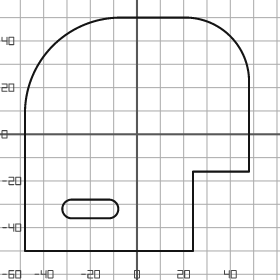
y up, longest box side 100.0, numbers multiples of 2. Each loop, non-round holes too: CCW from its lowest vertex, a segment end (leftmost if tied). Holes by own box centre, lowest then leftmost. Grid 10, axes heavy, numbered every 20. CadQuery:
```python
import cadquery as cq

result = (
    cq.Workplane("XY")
    .moveTo(-48.0, -50.0)
    .lineTo(24.0, -50.0)
    .lineTo(24.0, -16.0)
    .lineTo(48.0, -16.0)
    .lineTo(48.0, 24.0)
    .threePointArc((40.0, 42.0), (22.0, 50.0))
    .lineTo(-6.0, 50.0)
    .threePointArc((-36.0, 38.0), (-48.0, 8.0))
    .close()
    .moveTo(-28.0, -36.0)
    .lineTo(-12.0, -36.0)
    .threePointArc((-8.0, -32.0), (-12.0, -28.0))
    .lineTo(-28.0, -28.0)
    .threePointArc((-32.0, -32.0), (-28.0, -36.0))
    .close()
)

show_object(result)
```